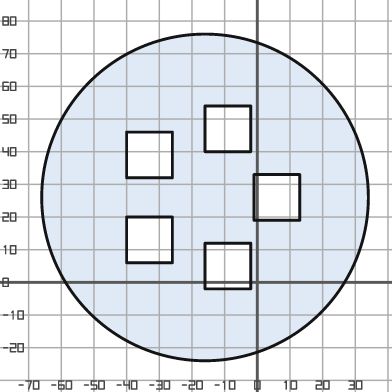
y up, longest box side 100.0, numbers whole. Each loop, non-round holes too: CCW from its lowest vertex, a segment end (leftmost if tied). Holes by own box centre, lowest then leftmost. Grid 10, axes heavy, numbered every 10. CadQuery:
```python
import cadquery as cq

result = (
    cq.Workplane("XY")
    .moveTo(-16.0, 26.0)
    .circle(50.0)
    .moveTo(-16.0, -2.0)
    .lineTo(-2.0, -2.0)
    .lineTo(-2.0, 12.0)
    .lineTo(-16.0, 12.0)
    .close()
    .moveTo(-40.0, 6.0)
    .lineTo(-26.0, 6.0)
    .lineTo(-26.0, 20.0)
    .lineTo(-40.0, 20.0)
    .close()
    .moveTo(-1.0, 19.0)
    .lineTo(13.0, 19.0)
    .lineTo(13.0, 33.0)
    .lineTo(-1.0, 33.0)
    .close()
    .moveTo(-40.0, 32.0)
    .lineTo(-26.0, 32.0)
    .lineTo(-26.0, 46.0)
    .lineTo(-40.0, 46.0)
    .close()
    .moveTo(-16.0, 40.0)
    .lineTo(-2.0, 40.0)
    .lineTo(-2.0, 54.0)
    .lineTo(-16.0, 54.0)
    .close()
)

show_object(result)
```